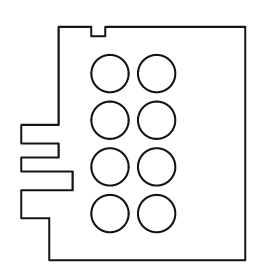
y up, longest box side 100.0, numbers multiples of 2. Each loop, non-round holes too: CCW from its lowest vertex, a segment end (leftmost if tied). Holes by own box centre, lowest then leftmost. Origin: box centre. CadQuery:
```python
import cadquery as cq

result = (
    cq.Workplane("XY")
    .moveTo(-36.0, -50.0)
    .lineTo(48.0, -50.0)
    .lineTo(48.0, 50.0)
    .lineTo(-12.0, 50.0)
    .lineTo(-12.0, 46.0)
    .lineTo(-18.0, 46.0)
    .lineTo(-18.0, 50.0)
    .lineTo(-32.0, 50.0)
    .lineTo(-32.0, 8.0)
    .lineTo(-48.0, 8.0)
    .lineTo(-48.0, 0.0)
    .lineTo(-32.0, 0.0)
    .lineTo(-32.0, -6.0)
    .lineTo(-48.0, -6.0)
    .lineTo(-48.0, -12.0)
    .lineTo(-26.0, -12.0)
    .lineTo(-26.0, -20.0)
    .lineTo(-48.0, -20.0)
    .lineTo(-48.0, -32.0)
    .lineTo(-36.0, -32.0)
    .close()
    .moveTo(-10.0, -30.0)
    .circle(8.0)
    .moveTo(10.0, -30.0)
    .circle(8.0)
    .moveTo(-10.0, -10.0)
    .circle(8.0)
    .moveTo(10.0, -10.0)
    .circle(8.0)
    .moveTo(-10.0, 10.0)
    .circle(8.0)
    .moveTo(10.0, 10.0)
    .circle(8.0)
    .moveTo(-10.0, 30.0)
    .circle(8.0)
    .moveTo(10.0, 30.0)
    .circle(8.0)
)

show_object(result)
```